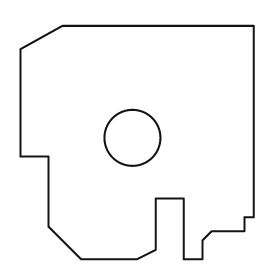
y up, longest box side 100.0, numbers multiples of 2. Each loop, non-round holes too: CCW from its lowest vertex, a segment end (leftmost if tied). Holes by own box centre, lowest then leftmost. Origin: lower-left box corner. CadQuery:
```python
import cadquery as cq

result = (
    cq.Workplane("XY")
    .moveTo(26.0, 0.0)
    .lineTo(50.0, 0.0)
    .lineTo(58.0, 4.0)
    .lineTo(58.0, 26.0)
    .lineTo(70.0, 26.0)
    .lineTo(70.0, 0.0)
    .lineTo(78.0, 0.0)
    .lineTo(78.0, 8.0)
    .lineTo(82.0, 12.0)
    .lineTo(96.0, 12.0)
    .lineTo(96.0, 18.0)
    .lineTo(100.0, 18.0)
    .lineTo(100.0, 100.0)
    .lineTo(18.0, 100.0)
    .lineTo(0.0, 90.0)
    .lineTo(0.0, 44.0)
    .lineTo(12.0, 44.0)
    .lineTo(12.0, 14.0)
    .close()
    .moveTo(48.0, 52.0)
    .circle(12.0)
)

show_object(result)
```